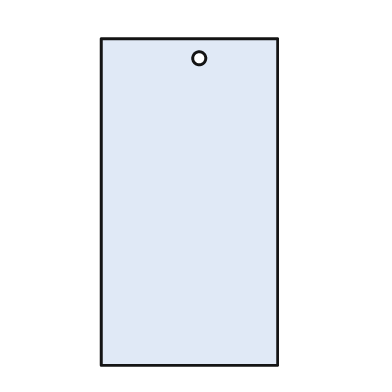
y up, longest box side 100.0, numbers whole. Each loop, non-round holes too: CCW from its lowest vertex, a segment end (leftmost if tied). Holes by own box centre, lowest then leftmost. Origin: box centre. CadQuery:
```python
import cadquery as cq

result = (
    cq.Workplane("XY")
    .moveTo(-27.0, -50.0)
    .lineTo(27.0, -50.0)
    .lineTo(27.0, 50.0)
    .lineTo(-27.0, 50.0)
    .close()
    .moveTo(3.0, 44.0)
    .circle(2.0)
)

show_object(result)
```